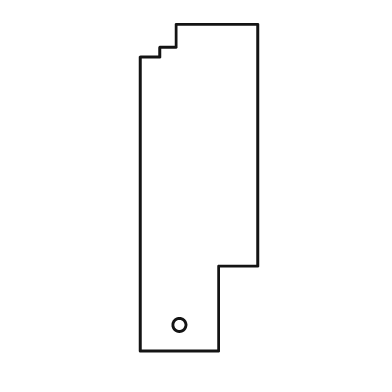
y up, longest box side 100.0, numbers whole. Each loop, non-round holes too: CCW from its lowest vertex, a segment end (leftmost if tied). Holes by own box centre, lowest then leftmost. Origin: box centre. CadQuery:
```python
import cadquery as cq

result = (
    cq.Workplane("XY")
    .moveTo(-18.0, -50.0)
    .lineTo(6.0, -50.0)
    .lineTo(6.0, -24.0)
    .lineTo(18.0, -24.0)
    .lineTo(18.0, 50.0)
    .lineTo(-7.0, 50.0)
    .lineTo(-7.0, 43.0)
    .lineTo(-12.0, 43.0)
    .lineTo(-12.0, 40.0)
    .lineTo(-18.0, 40.0)
    .close()
    .moveTo(-6.0, -42.0)
    .circle(2.0)
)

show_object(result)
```